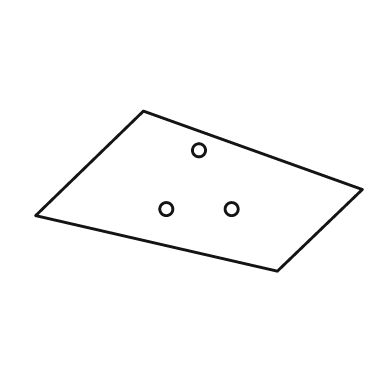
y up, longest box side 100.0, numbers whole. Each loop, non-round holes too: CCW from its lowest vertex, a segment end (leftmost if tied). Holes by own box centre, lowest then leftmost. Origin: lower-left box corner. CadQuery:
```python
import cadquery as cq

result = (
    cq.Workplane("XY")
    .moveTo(74.0, 0.0)
    .lineTo(100.0, 25.0)
    .lineTo(33.0, 49.0)
    .lineTo(0.0, 17.0)
    .close()
    .moveTo(40.0, 19.0)
    .circle(2.0)
    .moveTo(60.0, 19.0)
    .circle(2.0)
    .moveTo(50.0, 37.0)
    .circle(2.0)
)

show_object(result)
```